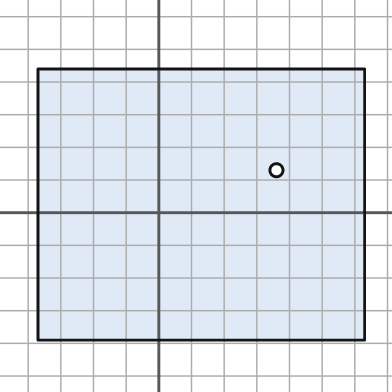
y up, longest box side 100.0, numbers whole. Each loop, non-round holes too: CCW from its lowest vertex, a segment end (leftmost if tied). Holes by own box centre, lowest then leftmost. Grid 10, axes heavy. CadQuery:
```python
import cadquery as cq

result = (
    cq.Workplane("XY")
    .moveTo(-37.0, -39.0)
    .lineTo(63.0, -39.0)
    .lineTo(63.0, 44.0)
    .lineTo(-37.0, 44.0)
    .close()
    .moveTo(36.0, 13.0)
    .circle(2.0)
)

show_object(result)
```